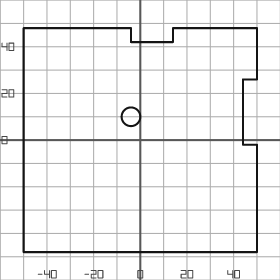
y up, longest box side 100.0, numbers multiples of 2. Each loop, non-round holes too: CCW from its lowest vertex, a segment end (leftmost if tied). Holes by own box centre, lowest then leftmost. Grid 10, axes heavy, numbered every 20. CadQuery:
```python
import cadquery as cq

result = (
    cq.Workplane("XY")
    .moveTo(-50.0, -48.0)
    .lineTo(50.0, -48.0)
    .lineTo(50.0, -2.0)
    .lineTo(44.0, -2.0)
    .lineTo(44.0, 26.0)
    .lineTo(50.0, 26.0)
    .lineTo(50.0, 48.0)
    .lineTo(14.0, 48.0)
    .lineTo(14.0, 42.0)
    .lineTo(-4.0, 42.0)
    .lineTo(-4.0, 48.0)
    .lineTo(-50.0, 48.0)
    .close()
    .moveTo(-4.0, 10.0)
    .circle(4.0)
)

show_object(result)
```